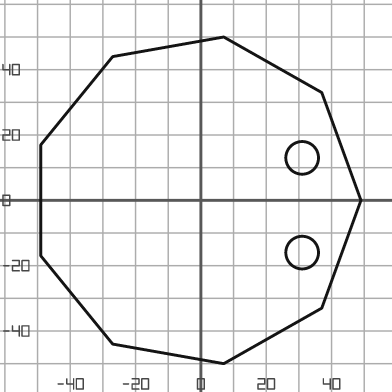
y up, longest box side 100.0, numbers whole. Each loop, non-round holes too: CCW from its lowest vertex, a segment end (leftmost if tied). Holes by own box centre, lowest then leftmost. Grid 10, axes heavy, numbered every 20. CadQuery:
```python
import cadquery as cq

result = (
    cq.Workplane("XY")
    .moveTo(7.0, -50.0)
    .lineTo(37.0, -33.0)
    .lineTo(49.0, 0.0)
    .lineTo(37.0, 33.0)
    .lineTo(7.0, 50.0)
    .lineTo(-27.0, 44.0)
    .lineTo(-49.0, 17.0)
    .lineTo(-49.0, -17.0)
    .lineTo(-27.0, -44.0)
    .close()
    .moveTo(31.0, -16.0)
    .circle(5.0)
    .moveTo(31.0, 13.0)
    .circle(5.0)
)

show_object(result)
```